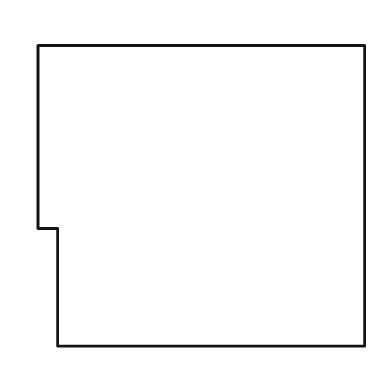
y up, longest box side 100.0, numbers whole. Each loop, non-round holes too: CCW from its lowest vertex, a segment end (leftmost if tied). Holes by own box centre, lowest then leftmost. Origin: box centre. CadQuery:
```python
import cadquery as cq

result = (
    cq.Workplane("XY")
    .moveTo(-44.0, -46.0)
    .lineTo(50.0, -46.0)
    .lineTo(50.0, 46.0)
    .lineTo(-50.0, 46.0)
    .lineTo(-50.0, -10.0)
    .lineTo(-44.0, -10.0)
    .close()
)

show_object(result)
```